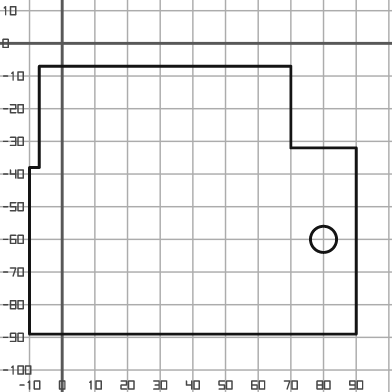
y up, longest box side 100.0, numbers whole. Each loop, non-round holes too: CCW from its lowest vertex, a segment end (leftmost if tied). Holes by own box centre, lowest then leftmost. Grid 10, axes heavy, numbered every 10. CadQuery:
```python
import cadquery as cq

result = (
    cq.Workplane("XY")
    .moveTo(-10.0, -89.0)
    .lineTo(90.0, -89.0)
    .lineTo(90.0, -32.0)
    .lineTo(70.0, -32.0)
    .lineTo(70.0, -7.0)
    .lineTo(-7.0, -7.0)
    .lineTo(-7.0, -38.0)
    .lineTo(-10.0, -38.0)
    .close()
    .moveTo(80.0, -60.0)
    .circle(4.0)
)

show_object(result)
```